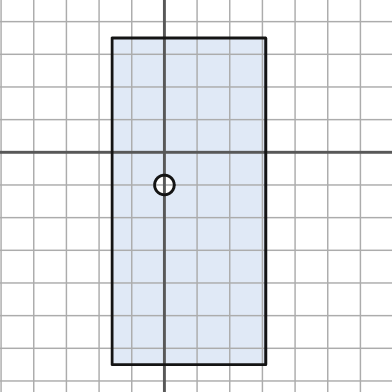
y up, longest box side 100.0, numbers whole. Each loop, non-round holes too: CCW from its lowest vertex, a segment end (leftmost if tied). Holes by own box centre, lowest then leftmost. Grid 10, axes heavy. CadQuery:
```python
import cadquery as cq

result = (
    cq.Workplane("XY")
    .moveTo(-16.0, -65.0)
    .lineTo(31.0, -65.0)
    .lineTo(31.0, 35.0)
    .lineTo(-16.0, 35.0)
    .close()
    .moveTo(0.0, -10.0)
    .circle(3.0)
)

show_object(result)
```